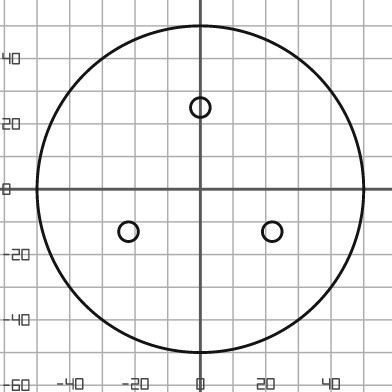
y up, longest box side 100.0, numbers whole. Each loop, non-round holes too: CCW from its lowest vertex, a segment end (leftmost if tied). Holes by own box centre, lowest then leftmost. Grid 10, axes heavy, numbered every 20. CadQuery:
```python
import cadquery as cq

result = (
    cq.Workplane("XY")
    .moveTo(0.0, 0.0)
    .circle(50.0)
    .moveTo(-22.0, -13.0)
    .circle(3.0)
    .moveTo(22.0, -13.0)
    .circle(3.0)
    .moveTo(0.0, 25.0)
    .circle(3.0)
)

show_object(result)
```